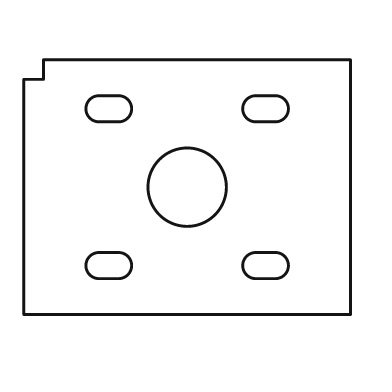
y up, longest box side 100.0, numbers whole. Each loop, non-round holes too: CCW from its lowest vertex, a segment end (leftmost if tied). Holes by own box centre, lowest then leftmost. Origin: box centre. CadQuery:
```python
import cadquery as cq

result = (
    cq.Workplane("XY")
    .moveTo(-50.0, -39.0)
    .lineTo(50.0, -39.0)
    .lineTo(50.0, 39.0)
    .lineTo(-44.0, 39.0)
    .lineTo(-44.0, 33.0)
    .lineTo(-50.0, 33.0)
    .close()
    .moveTo(-27.0, -28.0)
    .lineTo(-21.0, -28.0)
    .threePointArc((-17.0, -24.0), (-21.0, -20.0))
    .lineTo(-27.0, -20.0)
    .threePointArc((-31.0, -24.0), (-27.0, -28.0))
    .close()
    .moveTo(21.0, -28.0)
    .lineTo(27.0, -28.0)
    .threePointArc((31.0, -24.0), (27.0, -20.0))
    .lineTo(21.0, -20.0)
    .threePointArc((17.0, -24.0), (21.0, -28.0))
    .close()
    .moveTo(0.0, 0.0)
    .circle(12.0)
    .moveTo(-27.0, 20.0)
    .lineTo(-21.0, 20.0)
    .threePointArc((-17.0, 24.0), (-21.0, 28.0))
    .lineTo(-27.0, 28.0)
    .threePointArc((-31.0, 24.0), (-27.0, 20.0))
    .close()
    .moveTo(21.0, 20.0)
    .lineTo(27.0, 20.0)
    .threePointArc((31.0, 24.0), (27.0, 28.0))
    .lineTo(21.0, 28.0)
    .threePointArc((17.0, 24.0), (21.0, 20.0))
    .close()
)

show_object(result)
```